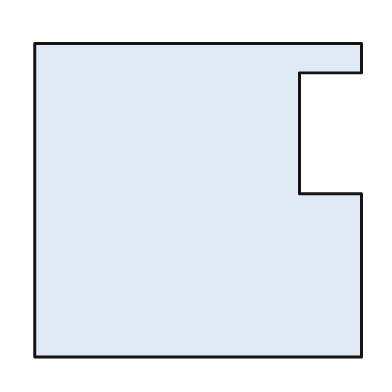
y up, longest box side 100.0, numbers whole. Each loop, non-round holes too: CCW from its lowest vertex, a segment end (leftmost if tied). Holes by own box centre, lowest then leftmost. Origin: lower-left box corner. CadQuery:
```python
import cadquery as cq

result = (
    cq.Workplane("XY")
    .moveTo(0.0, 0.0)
    .lineTo(100.0, 0.0)
    .lineTo(100.0, 50.0)
    .lineTo(81.0, 50.0)
    .lineTo(81.0, 87.0)
    .lineTo(100.0, 87.0)
    .lineTo(100.0, 96.0)
    .lineTo(0.0, 96.0)
    .close()
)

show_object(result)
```